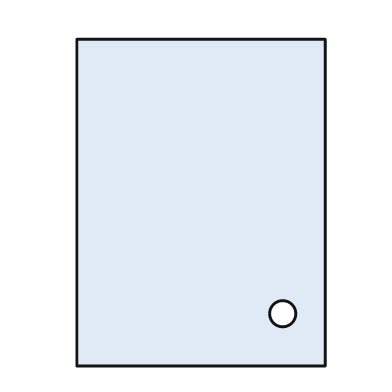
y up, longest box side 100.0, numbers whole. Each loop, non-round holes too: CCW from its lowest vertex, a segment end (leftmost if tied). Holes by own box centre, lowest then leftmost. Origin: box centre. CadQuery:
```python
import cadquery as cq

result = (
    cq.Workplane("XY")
    .moveTo(-38.0, -50.0)
    .lineTo(38.0, -50.0)
    .lineTo(38.0, 50.0)
    .lineTo(-38.0, 50.0)
    .close()
    .moveTo(25.0, -34.0)
    .circle(4.0)
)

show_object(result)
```